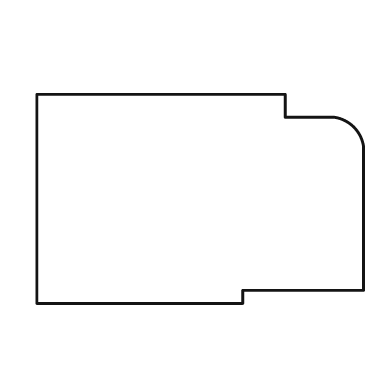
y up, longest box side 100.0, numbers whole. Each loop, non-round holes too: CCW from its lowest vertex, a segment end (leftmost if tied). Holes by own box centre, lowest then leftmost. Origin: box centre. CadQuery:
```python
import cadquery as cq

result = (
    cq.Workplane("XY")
    .moveTo(-50.0, -32.0)
    .lineTo(13.0, -32.0)
    .lineTo(13.0, -28.0)
    .lineTo(50.0, -28.0)
    .lineTo(50.0, 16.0)
    .threePointArc((47.0, 22.0), (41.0, 25.0))
    .lineTo(26.0, 25.0)
    .lineTo(26.0, 32.0)
    .lineTo(-50.0, 32.0)
    .close()
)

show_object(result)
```